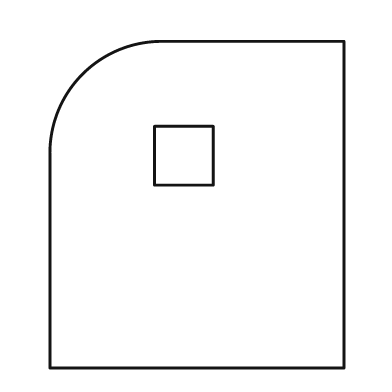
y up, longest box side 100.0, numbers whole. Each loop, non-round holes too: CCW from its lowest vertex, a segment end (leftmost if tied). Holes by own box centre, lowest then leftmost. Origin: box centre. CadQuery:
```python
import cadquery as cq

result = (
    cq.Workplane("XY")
    .moveTo(-45.0, -50.0)
    .lineTo(45.0, -50.0)
    .lineTo(45.0, 50.0)
    .lineTo(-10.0, 50.0)
    .threePointArc((-35.0, 40.0), (-45.0, 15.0))
    .close()
    .moveTo(-13.0, 6.0)
    .lineTo(5.0, 6.0)
    .lineTo(5.0, 24.0)
    .lineTo(-13.0, 24.0)
    .close()
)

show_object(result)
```